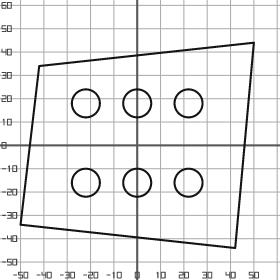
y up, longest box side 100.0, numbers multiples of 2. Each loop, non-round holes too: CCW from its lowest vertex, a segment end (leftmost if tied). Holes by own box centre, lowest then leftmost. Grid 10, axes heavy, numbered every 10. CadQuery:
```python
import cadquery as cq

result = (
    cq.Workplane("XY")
    .moveTo(42.0, -44.0)
    .lineTo(50.0, 44.0)
    .lineTo(-42.0, 34.0)
    .lineTo(-50.0, -34.0)
    .close()
    .moveTo(-22.0, -16.0)
    .circle(6.0)
    .moveTo(0.0, -16.0)
    .circle(6.0)
    .moveTo(22.0, -16.0)
    .circle(6.0)
    .moveTo(-22.0, 18.0)
    .circle(6.0)
    .moveTo(0.0, 18.0)
    .circle(6.0)
    .moveTo(22.0, 18.0)
    .circle(6.0)
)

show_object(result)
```